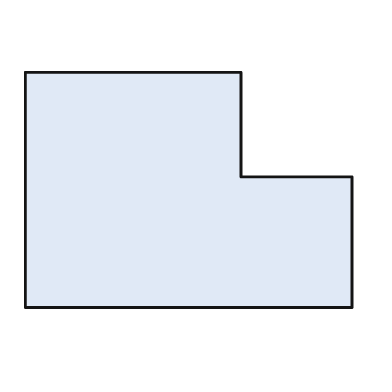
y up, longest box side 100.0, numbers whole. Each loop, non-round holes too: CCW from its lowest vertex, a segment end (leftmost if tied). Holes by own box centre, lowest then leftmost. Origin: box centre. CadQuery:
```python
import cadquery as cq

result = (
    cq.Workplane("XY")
    .moveTo(-50.0, -36.0)
    .lineTo(50.0, -36.0)
    .lineTo(50.0, 4.0)
    .lineTo(16.0, 4.0)
    .lineTo(16.0, 36.0)
    .lineTo(-50.0, 36.0)
    .close()
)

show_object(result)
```